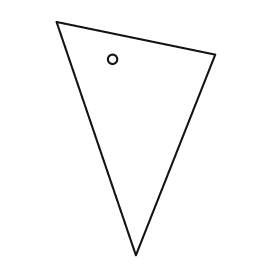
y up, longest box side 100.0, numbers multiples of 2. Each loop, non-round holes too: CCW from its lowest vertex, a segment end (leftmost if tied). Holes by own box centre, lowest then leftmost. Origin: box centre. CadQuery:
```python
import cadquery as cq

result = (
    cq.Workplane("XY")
    .moveTo(0.0, -50.0)
    .lineTo(34.0, 36.0)
    .lineTo(-34.0, 50.0)
    .close()
    .moveTo(-10.0, 34.0)
    .circle(2.0)
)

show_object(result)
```